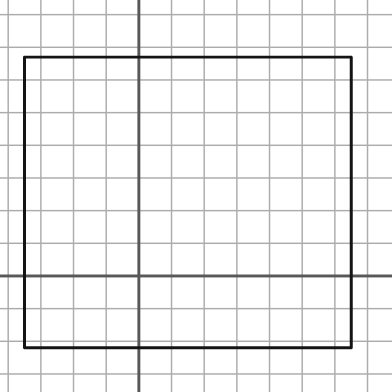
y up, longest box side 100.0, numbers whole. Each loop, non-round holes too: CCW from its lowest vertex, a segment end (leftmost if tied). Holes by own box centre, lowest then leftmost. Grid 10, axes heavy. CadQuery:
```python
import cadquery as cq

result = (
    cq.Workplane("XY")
    .moveTo(-35.0, -22.0)
    .lineTo(65.0, -22.0)
    .lineTo(65.0, 67.0)
    .lineTo(-35.0, 67.0)
    .close()
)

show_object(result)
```